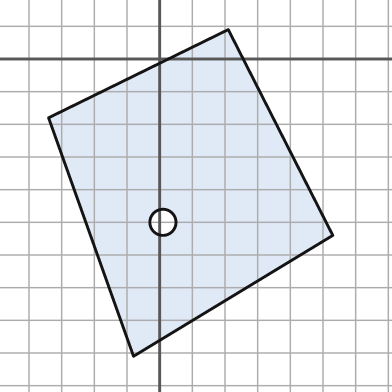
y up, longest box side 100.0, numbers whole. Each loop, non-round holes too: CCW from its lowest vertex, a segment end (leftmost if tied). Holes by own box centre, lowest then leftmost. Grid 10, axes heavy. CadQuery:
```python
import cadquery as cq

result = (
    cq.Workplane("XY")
    .moveTo(-8.0, -91.0)
    .lineTo(53.0, -54.0)
    .lineTo(21.0, 9.0)
    .lineTo(-34.0, -18.0)
    .close()
    .moveTo(1.0, -50.0)
    .circle(4.0)
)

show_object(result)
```